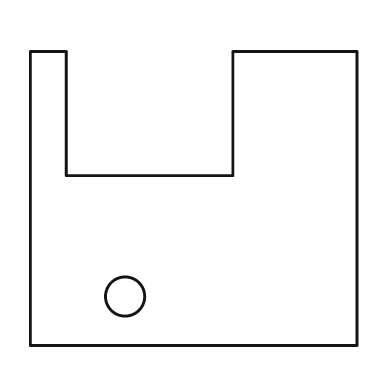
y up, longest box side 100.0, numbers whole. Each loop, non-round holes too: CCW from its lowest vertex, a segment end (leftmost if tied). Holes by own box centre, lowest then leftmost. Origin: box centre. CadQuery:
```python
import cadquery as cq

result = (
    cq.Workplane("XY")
    .moveTo(-50.0, -45.0)
    .lineTo(50.0, -45.0)
    .lineTo(50.0, 45.0)
    .lineTo(12.0, 45.0)
    .lineTo(12.0, 7.0)
    .lineTo(-39.0, 7.0)
    .lineTo(-39.0, 45.0)
    .lineTo(-50.0, 45.0)
    .close()
    .moveTo(-21.0, -30.0)
    .circle(6.0)
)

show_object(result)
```